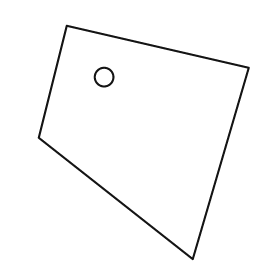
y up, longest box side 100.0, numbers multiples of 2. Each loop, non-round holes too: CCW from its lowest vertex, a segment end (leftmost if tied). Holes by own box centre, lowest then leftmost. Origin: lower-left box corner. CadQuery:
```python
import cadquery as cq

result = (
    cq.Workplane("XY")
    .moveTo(66.0, 0.0)
    .lineTo(90.0, 82.0)
    .lineTo(12.0, 100.0)
    .lineTo(0.0, 52.0)
    .close()
    .moveTo(28.0, 78.0)
    .circle(4.0)
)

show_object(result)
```